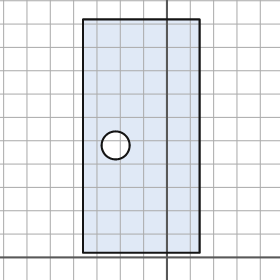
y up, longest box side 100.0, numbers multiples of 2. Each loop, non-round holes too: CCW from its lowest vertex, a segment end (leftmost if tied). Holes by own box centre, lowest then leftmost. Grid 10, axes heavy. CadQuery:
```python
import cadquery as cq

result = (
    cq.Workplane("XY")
    .moveTo(-36.0, 2.0)
    .lineTo(14.0, 2.0)
    .lineTo(14.0, 102.0)
    .lineTo(-36.0, 102.0)
    .close()
    .moveTo(-22.0, 48.0)
    .circle(6.0)
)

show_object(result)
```